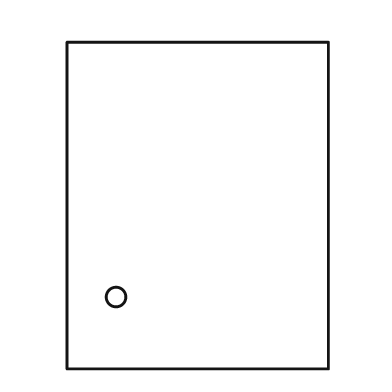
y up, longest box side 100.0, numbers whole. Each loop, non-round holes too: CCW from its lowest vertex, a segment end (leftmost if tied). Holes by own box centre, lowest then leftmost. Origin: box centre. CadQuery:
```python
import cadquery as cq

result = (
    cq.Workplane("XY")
    .moveTo(-40.0, -50.0)
    .lineTo(40.0, -50.0)
    .lineTo(40.0, 50.0)
    .lineTo(-40.0, 50.0)
    .close()
    .moveTo(-25.0, -28.0)
    .circle(3.0)
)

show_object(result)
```